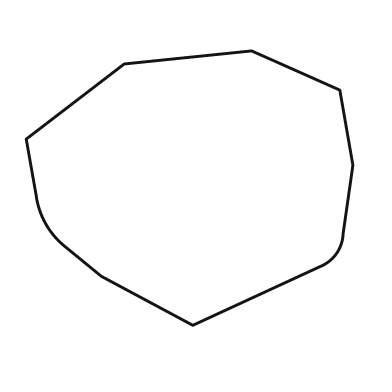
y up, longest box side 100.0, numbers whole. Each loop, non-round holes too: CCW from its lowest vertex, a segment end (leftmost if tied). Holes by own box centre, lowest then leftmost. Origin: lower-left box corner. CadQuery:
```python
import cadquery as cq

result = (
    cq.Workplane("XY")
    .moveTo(51.0, 0.0)
    .lineTo(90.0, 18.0)
    .threePointArc((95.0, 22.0), (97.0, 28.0))
    .lineTo(100.0, 49.0)
    .lineTo(96.0, 72.0)
    .lineTo(69.0, 84.0)
    .lineTo(30.0, 80.0)
    .lineTo(0.0, 57.0)
    .lineTo(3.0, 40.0)
    .threePointArc((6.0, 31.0), (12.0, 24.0))
    .lineTo(23.0, 15.0)
    .close()
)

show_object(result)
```